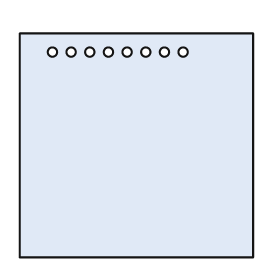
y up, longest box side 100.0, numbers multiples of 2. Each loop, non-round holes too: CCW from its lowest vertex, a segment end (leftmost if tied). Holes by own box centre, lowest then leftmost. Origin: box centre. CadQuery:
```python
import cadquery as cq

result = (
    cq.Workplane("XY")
    .moveTo(-50.0, -48.0)
    .lineTo(50.0, -48.0)
    .lineTo(50.0, 48.0)
    .lineTo(-50.0, 48.0)
    .close()
    .moveTo(-36.0, 40.0)
    .circle(2.0)
    .moveTo(-28.0, 40.0)
    .circle(2.0)
    .moveTo(-20.0, 40.0)
    .circle(2.0)
    .moveTo(-12.0, 40.0)
    .circle(2.0)
    .moveTo(-4.0, 40.0)
    .circle(2.0)
    .moveTo(4.0, 40.0)
    .circle(2.0)
    .moveTo(12.0, 40.0)
    .circle(2.0)
    .moveTo(20.0, 40.0)
    .circle(2.0)
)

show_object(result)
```